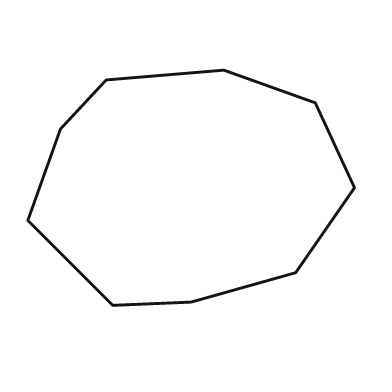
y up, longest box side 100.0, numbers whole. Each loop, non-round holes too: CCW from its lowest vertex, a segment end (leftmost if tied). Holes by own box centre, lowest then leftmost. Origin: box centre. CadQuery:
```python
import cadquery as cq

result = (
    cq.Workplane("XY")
    .moveTo(-24.0, -36.0)
    .lineTo(0.0, -35.0)
    .lineTo(32.0, -26.0)
    .lineTo(50.0, 0.0)
    .lineTo(38.0, 26.0)
    .lineTo(10.0, 36.0)
    .lineTo(-26.0, 33.0)
    .lineTo(-40.0, 18.0)
    .lineTo(-50.0, -10.0)
    .close()
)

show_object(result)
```